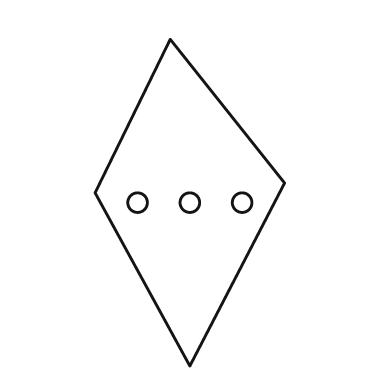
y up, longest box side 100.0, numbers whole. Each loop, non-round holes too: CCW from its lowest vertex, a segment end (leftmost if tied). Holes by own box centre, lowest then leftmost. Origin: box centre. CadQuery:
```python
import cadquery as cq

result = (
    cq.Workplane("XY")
    .moveTo(0.0, -50.0)
    .lineTo(29.0, 6.0)
    .lineTo(-6.0, 50.0)
    .lineTo(-29.0, 3.0)
    .close()
    .moveTo(-16.0, 0.0)
    .circle(3.0)
    .moveTo(0.0, 0.0)
    .circle(3.0)
    .moveTo(16.0, 0.0)
    .circle(3.0)
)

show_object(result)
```